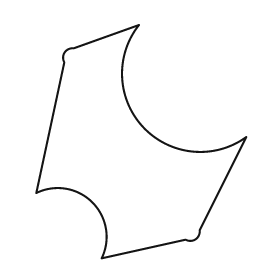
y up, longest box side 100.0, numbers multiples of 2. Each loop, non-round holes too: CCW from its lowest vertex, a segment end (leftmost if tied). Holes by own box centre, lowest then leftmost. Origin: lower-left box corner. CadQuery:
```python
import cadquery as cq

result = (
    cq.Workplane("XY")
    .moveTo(28.0, 0.0)
    .lineTo(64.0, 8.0)
    .threePointArc((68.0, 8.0), (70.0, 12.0))
    .lineTo(90.0, 52.0)
    .threePointArc((46.0, 56.0), (44.0, 100.0))
    .lineTo(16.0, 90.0)
    .threePointArc((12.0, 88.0), (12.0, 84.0))
    .lineTo(0.0, 28.0)
    .threePointArc((24.0, 24.0), (28.0, 0.0))
    .close()
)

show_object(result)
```